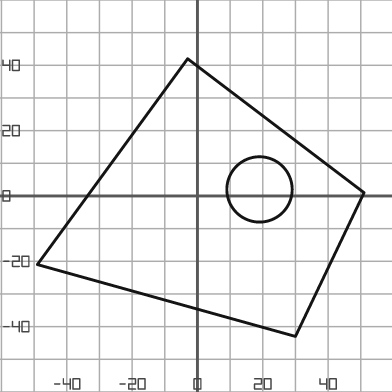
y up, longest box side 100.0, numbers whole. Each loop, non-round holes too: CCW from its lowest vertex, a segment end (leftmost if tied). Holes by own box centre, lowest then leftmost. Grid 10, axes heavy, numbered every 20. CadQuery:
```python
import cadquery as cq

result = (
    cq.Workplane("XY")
    .moveTo(30.0, -43.0)
    .lineTo(51.0, 1.0)
    .lineTo(-3.0, 42.0)
    .lineTo(-49.0, -21.0)
    .close()
    .moveTo(19.0, 2.0)
    .circle(10.0)
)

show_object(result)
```